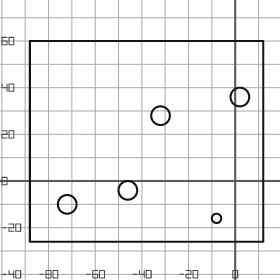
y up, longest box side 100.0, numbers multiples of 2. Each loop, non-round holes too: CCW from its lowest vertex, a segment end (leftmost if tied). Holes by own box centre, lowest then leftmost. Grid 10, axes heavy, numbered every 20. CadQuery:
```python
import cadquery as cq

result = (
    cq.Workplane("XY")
    .moveTo(-88.0, -26.0)
    .lineTo(12.0, -26.0)
    .lineTo(12.0, 60.0)
    .lineTo(-88.0, 60.0)
    .close()
    .moveTo(-8.0, -16.0)
    .circle(2.0)
    .moveTo(-72.0, -10.0)
    .circle(4.0)
    .moveTo(-46.0, -4.0)
    .circle(4.0)
    .moveTo(-32.0, 28.0)
    .circle(4.0)
    .moveTo(2.0, 36.0)
    .circle(4.0)
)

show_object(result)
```